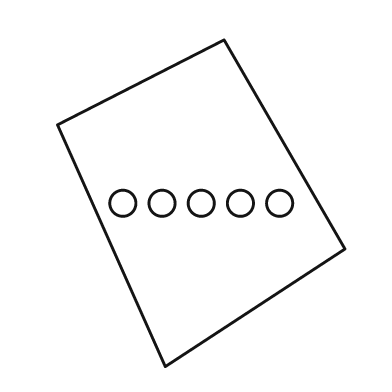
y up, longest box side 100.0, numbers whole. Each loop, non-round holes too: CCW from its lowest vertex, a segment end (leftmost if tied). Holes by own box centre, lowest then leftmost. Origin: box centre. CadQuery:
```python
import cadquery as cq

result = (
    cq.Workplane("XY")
    .moveTo(-11.0, -50.0)
    .lineTo(44.0, -14.0)
    .lineTo(7.0, 50.0)
    .lineTo(-44.0, 24.0)
    .close()
    .moveTo(-24.0, 0.0)
    .circle(4.0)
    .moveTo(-12.0, 0.0)
    .circle(4.0)
    .moveTo(0.0, 0.0)
    .circle(4.0)
    .moveTo(12.0, 0.0)
    .circle(4.0)
    .moveTo(24.0, 0.0)
    .circle(4.0)
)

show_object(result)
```